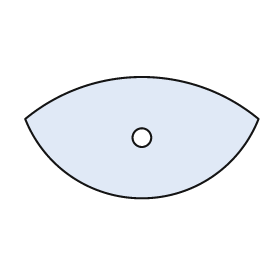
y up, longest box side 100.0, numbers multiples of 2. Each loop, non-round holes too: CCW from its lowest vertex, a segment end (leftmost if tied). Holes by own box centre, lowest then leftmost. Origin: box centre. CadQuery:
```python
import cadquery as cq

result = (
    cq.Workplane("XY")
    .moveTo(-50.0, 8.0)
    .threePointArc((0.0, -26.0), (50.0, 8.0))
    .threePointArc((0.0, 26.0), (-50.0, 8.0))
    .close()
    .moveTo(0.0, 0.0)
    .circle(4.0)
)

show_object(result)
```